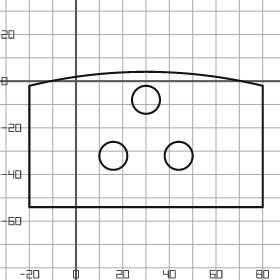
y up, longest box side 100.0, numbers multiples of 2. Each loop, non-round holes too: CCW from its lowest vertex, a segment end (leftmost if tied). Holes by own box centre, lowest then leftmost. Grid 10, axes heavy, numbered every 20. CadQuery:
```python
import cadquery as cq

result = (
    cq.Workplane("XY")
    .moveTo(-20.0, -54.0)
    .lineTo(80.0, -54.0)
    .lineTo(80.0, -2.0)
    .threePointArc((30.0, 4.0), (-20.0, -2.0))
    .close()
    .moveTo(16.0, -32.0)
    .circle(6.0)
    .moveTo(44.0, -32.0)
    .circle(6.0)
    .moveTo(30.0, -8.0)
    .circle(6.0)
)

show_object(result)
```